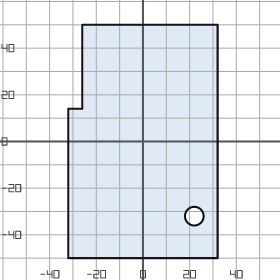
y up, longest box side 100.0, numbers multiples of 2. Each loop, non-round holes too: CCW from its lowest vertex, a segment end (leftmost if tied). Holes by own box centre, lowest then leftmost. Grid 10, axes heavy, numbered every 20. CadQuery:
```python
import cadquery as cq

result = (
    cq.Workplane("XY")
    .moveTo(-32.0, -50.0)
    .lineTo(32.0, -50.0)
    .lineTo(32.0, 50.0)
    .lineTo(-26.0, 50.0)
    .lineTo(-26.0, 14.0)
    .lineTo(-32.0, 14.0)
    .close()
    .moveTo(22.0, -32.0)
    .circle(4.0)
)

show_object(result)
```